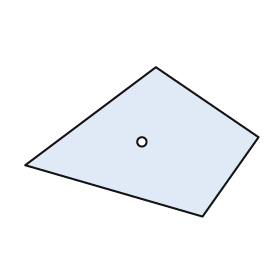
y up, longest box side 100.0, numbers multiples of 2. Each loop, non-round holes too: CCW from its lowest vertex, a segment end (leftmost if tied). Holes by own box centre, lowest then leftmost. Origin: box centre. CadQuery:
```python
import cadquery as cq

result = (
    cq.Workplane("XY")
    .moveTo(26.0, -32.0)
    .lineTo(50.0, 2.0)
    .lineTo(6.0, 32.0)
    .lineTo(-50.0, -10.0)
    .close()
    .moveTo(0.0, 0.0)
    .circle(2.0)
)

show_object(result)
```